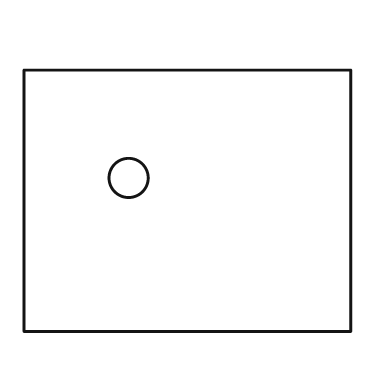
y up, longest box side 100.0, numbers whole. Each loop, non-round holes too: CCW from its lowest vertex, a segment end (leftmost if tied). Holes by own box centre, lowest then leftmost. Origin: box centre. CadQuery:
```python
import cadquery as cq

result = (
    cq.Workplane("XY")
    .moveTo(-50.0, -40.0)
    .lineTo(50.0, -40.0)
    .lineTo(50.0, 40.0)
    .lineTo(-50.0, 40.0)
    .close()
    .moveTo(-18.0, 7.0)
    .circle(6.0)
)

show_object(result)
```